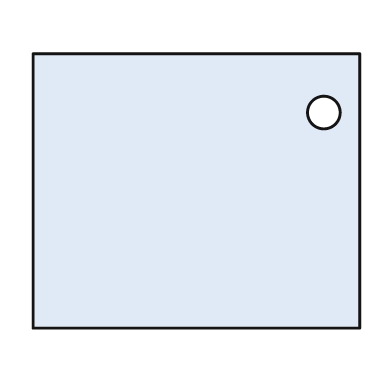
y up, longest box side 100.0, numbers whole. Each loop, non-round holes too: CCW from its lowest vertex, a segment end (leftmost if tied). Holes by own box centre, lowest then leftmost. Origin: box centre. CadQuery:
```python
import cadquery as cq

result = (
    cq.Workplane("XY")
    .moveTo(-50.0, -42.0)
    .lineTo(50.0, -42.0)
    .lineTo(50.0, 42.0)
    .lineTo(-50.0, 42.0)
    .close()
    .moveTo(39.0, 24.0)
    .circle(5.0)
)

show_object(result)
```